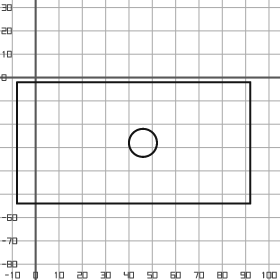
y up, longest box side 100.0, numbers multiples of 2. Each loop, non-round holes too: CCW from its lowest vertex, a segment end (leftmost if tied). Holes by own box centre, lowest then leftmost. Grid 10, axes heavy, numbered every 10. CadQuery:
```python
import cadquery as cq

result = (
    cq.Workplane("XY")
    .moveTo(-8.0, -54.0)
    .lineTo(92.0, -54.0)
    .lineTo(92.0, -2.0)
    .lineTo(-8.0, -2.0)
    .close()
    .moveTo(46.0, -28.0)
    .circle(6.0)
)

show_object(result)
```